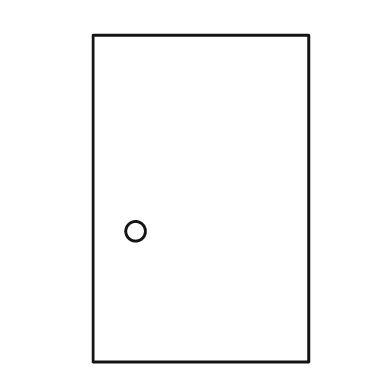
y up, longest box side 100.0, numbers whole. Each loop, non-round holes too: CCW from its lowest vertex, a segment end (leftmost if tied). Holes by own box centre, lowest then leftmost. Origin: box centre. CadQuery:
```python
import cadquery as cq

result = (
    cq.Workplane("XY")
    .moveTo(-33.0, -50.0)
    .lineTo(33.0, -50.0)
    .lineTo(33.0, 50.0)
    .lineTo(-33.0, 50.0)
    .close()
    .moveTo(-20.0, -10.0)
    .circle(3.0)
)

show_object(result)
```